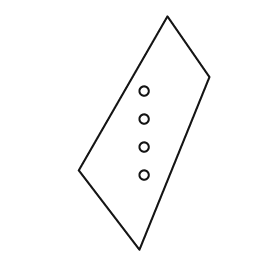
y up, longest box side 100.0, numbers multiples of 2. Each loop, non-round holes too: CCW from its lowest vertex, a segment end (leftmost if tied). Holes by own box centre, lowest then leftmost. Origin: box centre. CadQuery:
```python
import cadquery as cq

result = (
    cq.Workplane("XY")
    .moveTo(-2.0, -50.0)
    .lineTo(28.0, 24.0)
    .lineTo(10.0, 50.0)
    .lineTo(-28.0, -16.0)
    .close()
    .moveTo(0.0, -18.0)
    .circle(2.0)
    .moveTo(0.0, -6.0)
    .circle(2.0)
    .moveTo(0.0, 6.0)
    .circle(2.0)
    .moveTo(0.0, 18.0)
    .circle(2.0)
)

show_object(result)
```